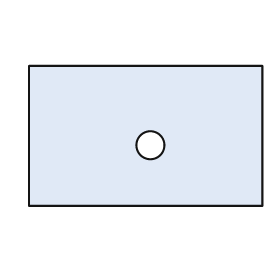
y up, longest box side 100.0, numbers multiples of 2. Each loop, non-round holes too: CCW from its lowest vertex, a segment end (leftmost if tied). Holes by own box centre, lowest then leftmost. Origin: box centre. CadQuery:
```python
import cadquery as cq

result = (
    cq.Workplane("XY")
    .moveTo(-50.0, -30.0)
    .lineTo(50.0, -30.0)
    .lineTo(50.0, 30.0)
    .lineTo(-50.0, 30.0)
    .close()
    .moveTo(2.0, -4.0)
    .circle(6.0)
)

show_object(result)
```